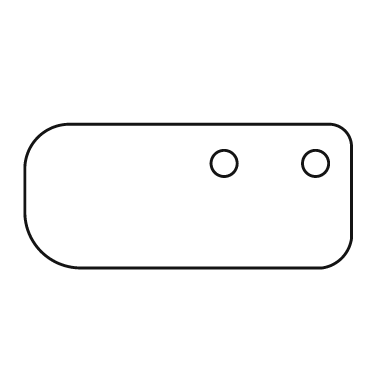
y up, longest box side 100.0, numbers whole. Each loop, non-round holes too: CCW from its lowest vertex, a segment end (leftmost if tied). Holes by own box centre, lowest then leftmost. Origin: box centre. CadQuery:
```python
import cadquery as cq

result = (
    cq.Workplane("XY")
    .moveTo(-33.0, -22.0)
    .lineTo(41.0, -22.0)
    .threePointArc((47.0, -19.0), (50.0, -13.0))
    .lineTo(50.0, 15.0)
    .threePointArc((48.0, 20.0), (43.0, 22.0))
    .lineTo(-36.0, 22.0)
    .threePointArc((-46.0, 18.0), (-50.0, 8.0))
    .lineTo(-50.0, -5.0)
    .threePointArc((-45.0, -17.0), (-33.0, -22.0))
    .close()
    .moveTo(11.0, 10.0)
    .circle(4.0)
    .moveTo(39.0, 10.0)
    .circle(4.0)
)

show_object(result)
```